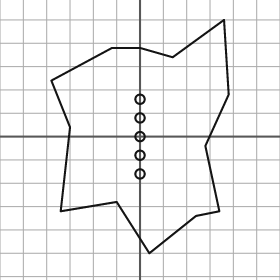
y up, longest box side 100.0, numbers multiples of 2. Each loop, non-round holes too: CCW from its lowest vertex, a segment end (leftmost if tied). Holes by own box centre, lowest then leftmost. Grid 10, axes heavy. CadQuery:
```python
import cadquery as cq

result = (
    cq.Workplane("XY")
    .moveTo(4.0, -50.0)
    .lineTo(24.0, -34.0)
    .lineTo(34.0, -32.0)
    .lineTo(28.0, -4.0)
    .lineTo(38.0, 18.0)
    .lineTo(36.0, 50.0)
    .lineTo(14.0, 34.0)
    .lineTo(0.0, 38.0)
    .lineTo(-12.0, 38.0)
    .lineTo(-38.0, 24.0)
    .lineTo(-30.0, 4.0)
    .lineTo(-34.0, -32.0)
    .lineTo(-10.0, -28.0)
    .close()
    .moveTo(0.0, -16.0)
    .circle(2.0)
    .moveTo(0.0, -8.0)
    .circle(2.0)
    .moveTo(0.0, 0.0)
    .circle(2.0)
    .moveTo(0.0, 8.0)
    .circle(2.0)
    .moveTo(0.0, 16.0)
    .circle(2.0)
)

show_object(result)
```